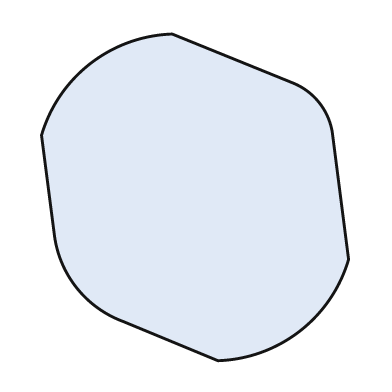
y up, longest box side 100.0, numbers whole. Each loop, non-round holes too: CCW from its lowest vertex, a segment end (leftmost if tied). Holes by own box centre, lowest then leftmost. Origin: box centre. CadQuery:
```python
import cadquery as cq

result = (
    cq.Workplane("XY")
    .moveTo(7.0, -50.0)
    .threePointArc((32.0, -41.0), (47.0, -19.0))
    .lineTo(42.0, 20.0)
    .threePointArc((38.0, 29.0), (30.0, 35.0))
    .lineTo(-7.0, 50.0)
    .threePointArc((-32.0, 41.0), (-47.0, 19.0))
    .lineTo(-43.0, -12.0)
    .threePointArc((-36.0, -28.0), (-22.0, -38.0))
    .close()
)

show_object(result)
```